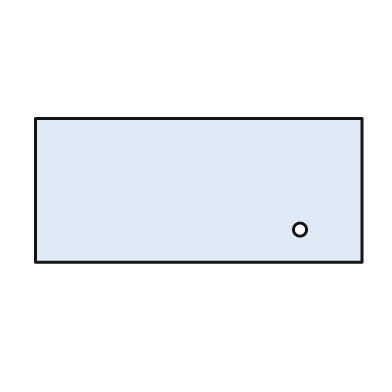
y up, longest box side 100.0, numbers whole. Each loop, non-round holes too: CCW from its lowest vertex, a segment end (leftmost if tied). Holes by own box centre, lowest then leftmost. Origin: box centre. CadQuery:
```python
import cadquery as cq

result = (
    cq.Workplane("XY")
    .moveTo(-50.0, -22.0)
    .lineTo(50.0, -22.0)
    .lineTo(50.0, 22.0)
    .lineTo(-50.0, 22.0)
    .close()
    .moveTo(31.0, -12.0)
    .circle(2.0)
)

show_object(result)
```